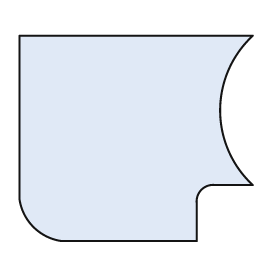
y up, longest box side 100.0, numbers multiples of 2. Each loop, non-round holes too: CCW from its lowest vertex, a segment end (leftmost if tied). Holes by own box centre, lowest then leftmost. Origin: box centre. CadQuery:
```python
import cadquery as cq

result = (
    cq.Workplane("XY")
    .moveTo(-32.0, -44.0)
    .lineTo(26.0, -44.0)
    .lineTo(26.0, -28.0)
    .threePointArc((28.0, -22.0), (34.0, -20.0))
    .lineTo(50.0, -20.0)
    .threePointArc((36.0, 12.0), (50.0, 44.0))
    .lineTo(-50.0, 44.0)
    .lineTo(-50.0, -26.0)
    .threePointArc((-44.0, -38.0), (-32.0, -44.0))
    .close()
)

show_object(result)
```